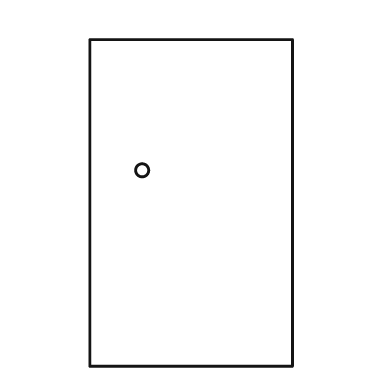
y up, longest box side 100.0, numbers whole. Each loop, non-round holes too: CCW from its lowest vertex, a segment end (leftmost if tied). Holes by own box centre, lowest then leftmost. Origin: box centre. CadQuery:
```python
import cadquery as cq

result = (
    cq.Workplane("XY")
    .moveTo(-31.0, -50.0)
    .lineTo(31.0, -50.0)
    .lineTo(31.0, 50.0)
    .lineTo(-31.0, 50.0)
    .close()
    .moveTo(-15.0, 10.0)
    .circle(2.0)
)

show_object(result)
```